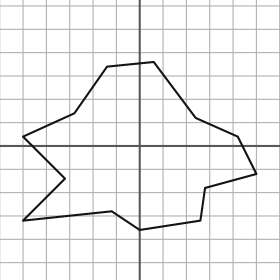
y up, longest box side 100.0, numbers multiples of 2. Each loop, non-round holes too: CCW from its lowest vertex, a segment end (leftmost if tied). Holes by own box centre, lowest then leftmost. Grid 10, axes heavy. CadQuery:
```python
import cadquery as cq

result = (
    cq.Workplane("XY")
    .moveTo(0.0, -36.0)
    .lineTo(26.0, -32.0)
    .lineTo(28.0, -18.0)
    .lineTo(50.0, -12.0)
    .lineTo(42.0, 4.0)
    .lineTo(24.0, 12.0)
    .lineTo(6.0, 36.0)
    .lineTo(-14.0, 34.0)
    .lineTo(-28.0, 14.0)
    .lineTo(-50.0, 4.0)
    .lineTo(-32.0, -14.0)
    .lineTo(-50.0, -32.0)
    .lineTo(-12.0, -28.0)
    .close()
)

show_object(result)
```